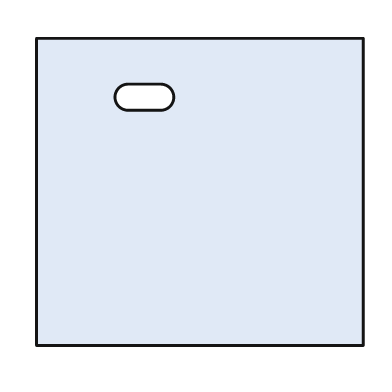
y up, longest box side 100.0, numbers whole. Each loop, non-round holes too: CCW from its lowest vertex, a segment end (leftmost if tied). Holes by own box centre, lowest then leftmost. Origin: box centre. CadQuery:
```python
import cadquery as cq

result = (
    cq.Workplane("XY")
    .moveTo(-50.0, -47.0)
    .lineTo(50.0, -47.0)
    .lineTo(50.0, 47.0)
    .lineTo(-50.0, 47.0)
    .close()
    .moveTo(-22.0, 25.0)
    .lineTo(-12.0, 25.0)
    .threePointArc((-8.0, 29.0), (-12.0, 33.0))
    .lineTo(-22.0, 33.0)
    .threePointArc((-26.0, 29.0), (-22.0, 25.0))
    .close()
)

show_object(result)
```